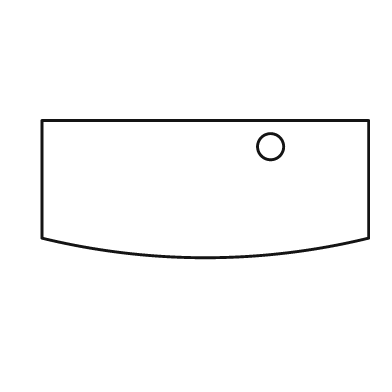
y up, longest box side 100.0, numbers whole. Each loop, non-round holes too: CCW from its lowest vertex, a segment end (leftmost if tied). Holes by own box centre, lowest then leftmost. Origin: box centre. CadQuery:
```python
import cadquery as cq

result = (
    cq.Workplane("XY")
    .moveTo(-50.0, -15.0)
    .threePointArc((0.0, -21.0), (50.0, -15.0))
    .lineTo(50.0, 21.0)
    .lineTo(-50.0, 21.0)
    .close()
    .moveTo(20.0, 13.0)
    .circle(4.0)
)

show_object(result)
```